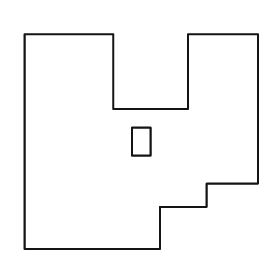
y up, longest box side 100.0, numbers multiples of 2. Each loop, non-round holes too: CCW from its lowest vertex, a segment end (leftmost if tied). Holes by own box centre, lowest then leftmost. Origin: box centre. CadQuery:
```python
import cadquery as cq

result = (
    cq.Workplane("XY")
    .moveTo(-50.0, -46.0)
    .lineTo(8.0, -46.0)
    .lineTo(8.0, -28.0)
    .lineTo(28.0, -28.0)
    .lineTo(28.0, -18.0)
    .lineTo(50.0, -18.0)
    .lineTo(50.0, 46.0)
    .lineTo(20.0, 46.0)
    .lineTo(20.0, 14.0)
    .lineTo(-12.0, 14.0)
    .lineTo(-12.0, 46.0)
    .lineTo(-50.0, 46.0)
    .close()
    .moveTo(-4.0, -6.0)
    .lineTo(4.0, -6.0)
    .lineTo(4.0, 6.0)
    .lineTo(-4.0, 6.0)
    .close()
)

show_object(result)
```